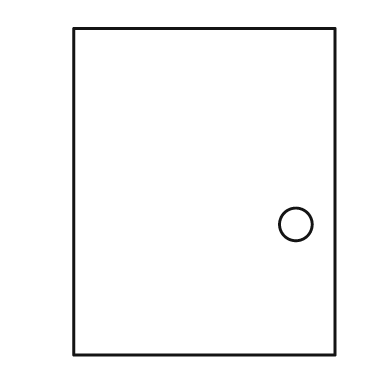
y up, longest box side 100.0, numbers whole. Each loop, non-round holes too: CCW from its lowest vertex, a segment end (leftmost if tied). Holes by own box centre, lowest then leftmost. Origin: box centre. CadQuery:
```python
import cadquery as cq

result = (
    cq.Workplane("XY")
    .moveTo(-40.0, -50.0)
    .lineTo(40.0, -50.0)
    .lineTo(40.0, 50.0)
    .lineTo(-40.0, 50.0)
    .close()
    .moveTo(28.0, -10.0)
    .circle(5.0)
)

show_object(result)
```